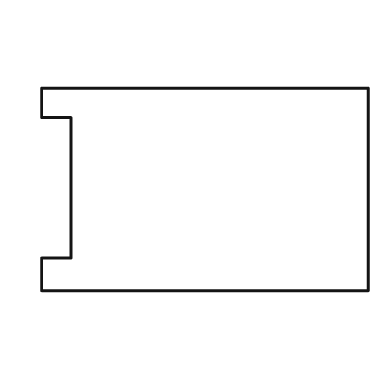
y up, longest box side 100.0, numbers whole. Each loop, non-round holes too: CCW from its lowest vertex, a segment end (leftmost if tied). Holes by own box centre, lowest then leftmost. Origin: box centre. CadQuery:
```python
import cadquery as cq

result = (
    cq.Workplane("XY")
    .moveTo(-50.0, -31.0)
    .lineTo(50.0, -31.0)
    .lineTo(50.0, 31.0)
    .lineTo(-50.0, 31.0)
    .lineTo(-50.0, 22.0)
    .lineTo(-41.0, 22.0)
    .lineTo(-41.0, -21.0)
    .lineTo(-50.0, -21.0)
    .close()
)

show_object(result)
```